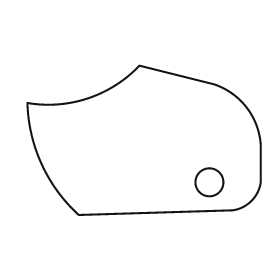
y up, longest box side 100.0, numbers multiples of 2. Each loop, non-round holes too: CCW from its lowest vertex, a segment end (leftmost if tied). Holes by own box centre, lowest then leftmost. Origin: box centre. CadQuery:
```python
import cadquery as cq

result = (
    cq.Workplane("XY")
    .moveTo(-28.0, -32.0)
    .lineTo(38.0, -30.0)
    .threePointArc((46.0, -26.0), (50.0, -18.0))
    .lineTo(50.0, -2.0)
    .threePointArc((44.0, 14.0), (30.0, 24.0))
    .lineTo(-2.0, 32.0)
    .threePointArc((-24.0, 18.0), (-50.0, 16.0))
    .threePointArc((-44.0, -10.0), (-28.0, -32.0))
    .close()
    .moveTo(28.0, -18.0)
    .circle(6.0)
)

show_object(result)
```